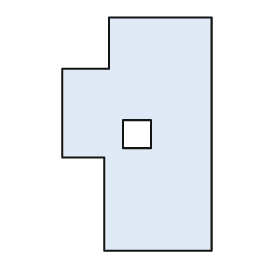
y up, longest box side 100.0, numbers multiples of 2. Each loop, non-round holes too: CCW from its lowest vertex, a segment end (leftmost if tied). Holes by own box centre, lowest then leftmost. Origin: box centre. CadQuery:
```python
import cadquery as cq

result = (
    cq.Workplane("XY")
    .moveTo(-14.0, -50.0)
    .lineTo(32.0, -50.0)
    .lineTo(32.0, 50.0)
    .lineTo(-12.0, 50.0)
    .lineTo(-12.0, 28.0)
    .lineTo(-32.0, 28.0)
    .lineTo(-32.0, -10.0)
    .lineTo(-14.0, -10.0)
    .close()
    .moveTo(-6.0, -6.0)
    .lineTo(6.0, -6.0)
    .lineTo(6.0, 6.0)
    .lineTo(-6.0, 6.0)
    .close()
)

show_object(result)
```